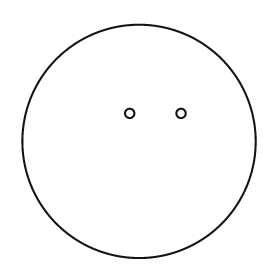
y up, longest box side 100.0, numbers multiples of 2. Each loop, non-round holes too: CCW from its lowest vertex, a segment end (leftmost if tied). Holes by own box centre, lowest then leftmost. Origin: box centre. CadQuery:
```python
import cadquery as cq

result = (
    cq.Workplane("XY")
    .moveTo(0.0, 0.0)
    .circle(50.0)
    .moveTo(-4.0, 12.0)
    .circle(2.0)
    .moveTo(18.0, 12.0)
    .circle(2.0)
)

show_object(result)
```